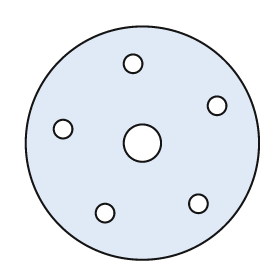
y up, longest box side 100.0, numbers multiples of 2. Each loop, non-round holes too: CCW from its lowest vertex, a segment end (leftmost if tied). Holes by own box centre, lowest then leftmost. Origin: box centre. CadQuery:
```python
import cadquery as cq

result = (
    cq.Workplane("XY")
    .moveTo(0.0, 0.0)
    .circle(50.0)
    .moveTo(-16.0, -30.0)
    .circle(4.0)
    .moveTo(24.0, -26.0)
    .circle(4.0)
    .moveTo(0.0, 0.0)
    .circle(8.0)
    .moveTo(-34.0, 6.0)
    .circle(4.0)
    .moveTo(32.0, 16.0)
    .circle(4.0)
    .moveTo(-4.0, 34.0)
    .circle(4.0)
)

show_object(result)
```